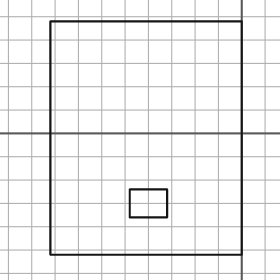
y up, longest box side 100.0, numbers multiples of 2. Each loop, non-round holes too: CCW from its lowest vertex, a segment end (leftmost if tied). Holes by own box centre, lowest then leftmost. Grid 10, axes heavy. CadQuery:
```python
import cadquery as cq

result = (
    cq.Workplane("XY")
    .moveTo(-82.0, -52.0)
    .lineTo(0.0, -52.0)
    .lineTo(0.0, 48.0)
    .lineTo(-82.0, 48.0)
    .close()
    .moveTo(-48.0, -36.0)
    .lineTo(-32.0, -36.0)
    .lineTo(-32.0, -24.0)
    .lineTo(-48.0, -24.0)
    .close()
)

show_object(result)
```